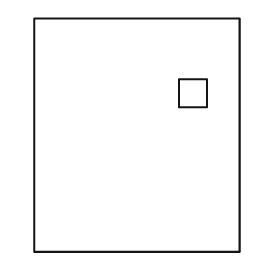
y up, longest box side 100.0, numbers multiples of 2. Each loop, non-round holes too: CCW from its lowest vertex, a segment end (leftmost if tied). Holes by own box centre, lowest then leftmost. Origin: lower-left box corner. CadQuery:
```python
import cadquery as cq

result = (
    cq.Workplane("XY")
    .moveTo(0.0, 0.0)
    .lineTo(88.0, 0.0)
    .lineTo(88.0, 100.0)
    .lineTo(0.0, 100.0)
    .close()
    .moveTo(62.0, 62.0)
    .lineTo(74.0, 62.0)
    .lineTo(74.0, 74.0)
    .lineTo(62.0, 74.0)
    .close()
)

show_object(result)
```